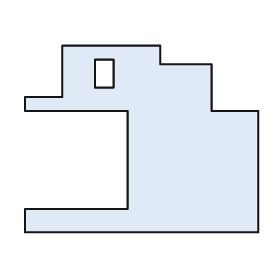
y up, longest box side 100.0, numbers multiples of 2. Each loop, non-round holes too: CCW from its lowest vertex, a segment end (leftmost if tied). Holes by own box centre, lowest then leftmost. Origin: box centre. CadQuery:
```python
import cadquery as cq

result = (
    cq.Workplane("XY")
    .moveTo(-50.0, -40.0)
    .lineTo(50.0, -40.0)
    .lineTo(50.0, 12.0)
    .lineTo(30.0, 12.0)
    .lineTo(30.0, 32.0)
    .lineTo(8.0, 32.0)
    .lineTo(8.0, 40.0)
    .lineTo(-34.0, 40.0)
    .lineTo(-34.0, 18.0)
    .lineTo(-50.0, 18.0)
    .lineTo(-50.0, 12.0)
    .lineTo(-6.0, 12.0)
    .lineTo(-6.0, -30.0)
    .lineTo(-50.0, -30.0)
    .close()
    .moveTo(-20.0, 22.0)
    .lineTo(-12.0, 22.0)
    .lineTo(-12.0, 34.0)
    .lineTo(-20.0, 34.0)
    .close()
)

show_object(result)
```